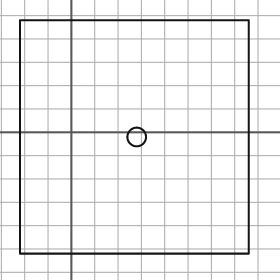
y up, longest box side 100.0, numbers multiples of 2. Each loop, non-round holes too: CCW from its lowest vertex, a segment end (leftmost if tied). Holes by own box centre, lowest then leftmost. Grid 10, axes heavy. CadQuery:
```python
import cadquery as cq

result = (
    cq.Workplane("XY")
    .moveTo(-22.0, -52.0)
    .lineTo(76.0, -52.0)
    .lineTo(76.0, 48.0)
    .lineTo(-22.0, 48.0)
    .close()
    .moveTo(28.0, -2.0)
    .circle(4.0)
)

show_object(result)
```